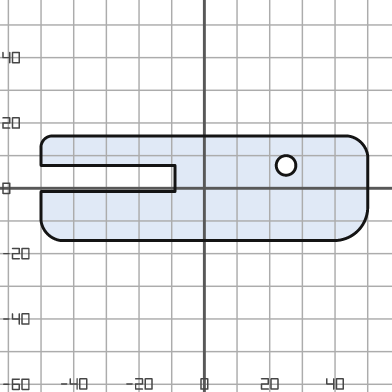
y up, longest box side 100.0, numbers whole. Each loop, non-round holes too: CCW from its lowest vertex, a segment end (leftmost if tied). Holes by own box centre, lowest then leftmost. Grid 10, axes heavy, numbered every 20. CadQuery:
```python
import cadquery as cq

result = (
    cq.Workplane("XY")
    .moveTo(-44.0, -16.0)
    .lineTo(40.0, -16.0)
    .threePointArc((47.0, -13.0), (50.0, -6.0))
    .lineTo(50.0, 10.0)
    .threePointArc((48.0, 14.0), (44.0, 16.0))
    .lineTo(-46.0, 16.0)
    .threePointArc((-49.0, 15.0), (-50.0, 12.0))
    .lineTo(-50.0, 7.0)
    .lineTo(-9.0, 7.0)
    .lineTo(-9.0, -1.0)
    .lineTo(-50.0, -1.0)
    .lineTo(-50.0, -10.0)
    .threePointArc((-48.0, -14.0), (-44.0, -16.0))
    .close()
    .moveTo(25.0, 7.0)
    .circle(3.0)
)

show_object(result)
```